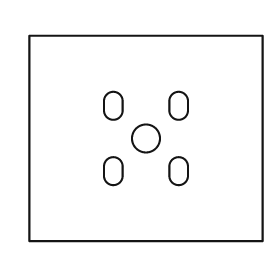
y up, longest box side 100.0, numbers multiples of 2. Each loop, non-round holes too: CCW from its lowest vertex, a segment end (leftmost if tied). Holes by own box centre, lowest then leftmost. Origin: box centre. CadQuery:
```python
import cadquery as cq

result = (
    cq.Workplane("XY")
    .moveTo(-50.0, -44.0)
    .lineTo(50.0, -44.0)
    .lineTo(50.0, 44.0)
    .lineTo(-50.0, 44.0)
    .close()
    .moveTo(-18.0, -16.0)
    .threePointArc((-14.0, -20.0), (-10.0, -16.0))
    .lineTo(-10.0, -12.0)
    .threePointArc((-14.0, -8.0), (-18.0, -12.0))
    .close()
    .moveTo(10.0, -16.0)
    .threePointArc((14.0, -20.0), (18.0, -16.0))
    .lineTo(18.0, -12.0)
    .threePointArc((14.0, -8.0), (10.0, -12.0))
    .close()
    .moveTo(0.0, 0.0)
    .circle(6.0)
    .moveTo(-18.0, 12.0)
    .threePointArc((-14.0, 8.0), (-10.0, 12.0))
    .lineTo(-10.0, 16.0)
    .threePointArc((-14.0, 20.0), (-18.0, 16.0))
    .close()
    .moveTo(10.0, 12.0)
    .threePointArc((14.0, 8.0), (18.0, 12.0))
    .lineTo(18.0, 16.0)
    .threePointArc((14.0, 20.0), (10.0, 16.0))
    .close()
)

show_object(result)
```